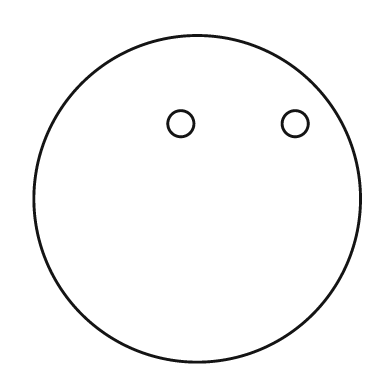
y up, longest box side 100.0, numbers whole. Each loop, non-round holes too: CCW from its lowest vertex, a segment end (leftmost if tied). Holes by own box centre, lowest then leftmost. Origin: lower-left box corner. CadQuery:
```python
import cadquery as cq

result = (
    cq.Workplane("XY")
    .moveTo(50.0, 50.0)
    .circle(50.0)
    .moveTo(45.0, 73.0)
    .circle(4.0)
    .moveTo(80.0, 73.0)
    .circle(4.0)
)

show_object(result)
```